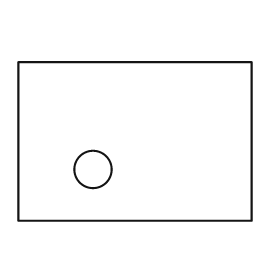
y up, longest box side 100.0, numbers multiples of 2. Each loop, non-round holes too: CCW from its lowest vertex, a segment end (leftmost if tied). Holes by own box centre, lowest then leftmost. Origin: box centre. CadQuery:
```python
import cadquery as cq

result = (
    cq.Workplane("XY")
    .moveTo(-50.0, -34.0)
    .lineTo(50.0, -34.0)
    .lineTo(50.0, 34.0)
    .lineTo(-50.0, 34.0)
    .close()
    .moveTo(-18.0, -12.0)
    .circle(8.0)
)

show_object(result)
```